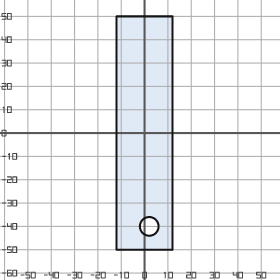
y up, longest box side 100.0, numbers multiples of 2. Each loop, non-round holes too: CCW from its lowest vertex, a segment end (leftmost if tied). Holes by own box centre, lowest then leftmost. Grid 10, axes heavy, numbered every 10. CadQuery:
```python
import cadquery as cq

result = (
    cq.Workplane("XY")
    .moveTo(-12.0, -50.0)
    .lineTo(12.0, -50.0)
    .lineTo(12.0, 50.0)
    .lineTo(-12.0, 50.0)
    .close()
    .moveTo(2.0, -40.0)
    .circle(4.0)
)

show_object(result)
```